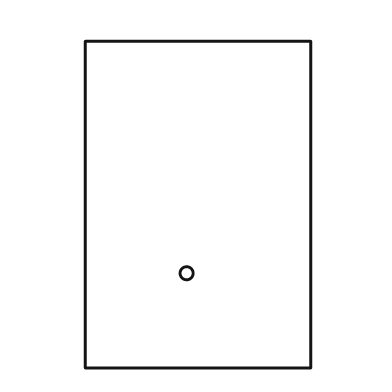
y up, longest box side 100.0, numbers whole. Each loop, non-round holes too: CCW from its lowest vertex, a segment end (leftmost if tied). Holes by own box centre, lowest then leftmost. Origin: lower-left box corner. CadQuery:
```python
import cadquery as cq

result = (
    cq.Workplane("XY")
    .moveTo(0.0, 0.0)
    .lineTo(69.0, 0.0)
    .lineTo(69.0, 100.0)
    .lineTo(0.0, 100.0)
    .close()
    .moveTo(31.0, 29.0)
    .circle(2.0)
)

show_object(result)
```